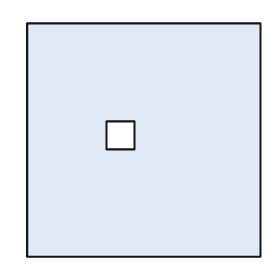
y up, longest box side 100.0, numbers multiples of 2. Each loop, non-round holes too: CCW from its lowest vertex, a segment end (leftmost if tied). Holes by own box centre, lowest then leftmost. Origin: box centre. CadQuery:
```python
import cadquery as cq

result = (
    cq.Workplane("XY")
    .moveTo(-50.0, -50.0)
    .lineTo(50.0, -50.0)
    .lineTo(50.0, 50.0)
    .lineTo(-50.0, 50.0)
    .close()
    .moveTo(-16.0, -4.0)
    .lineTo(-4.0, -4.0)
    .lineTo(-4.0, 8.0)
    .lineTo(-16.0, 8.0)
    .close()
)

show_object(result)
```